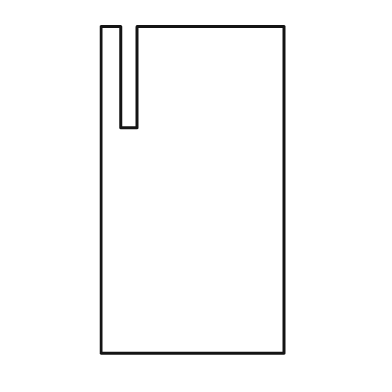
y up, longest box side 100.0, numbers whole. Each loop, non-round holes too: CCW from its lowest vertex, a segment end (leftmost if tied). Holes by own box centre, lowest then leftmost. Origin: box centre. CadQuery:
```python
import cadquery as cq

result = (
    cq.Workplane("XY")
    .moveTo(-28.0, -50.0)
    .lineTo(28.0, -50.0)
    .lineTo(28.0, 50.0)
    .lineTo(-17.0, 50.0)
    .lineTo(-17.0, 19.0)
    .lineTo(-22.0, 19.0)
    .lineTo(-22.0, 50.0)
    .lineTo(-28.0, 50.0)
    .close()
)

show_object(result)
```